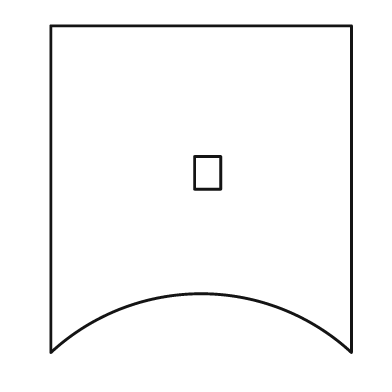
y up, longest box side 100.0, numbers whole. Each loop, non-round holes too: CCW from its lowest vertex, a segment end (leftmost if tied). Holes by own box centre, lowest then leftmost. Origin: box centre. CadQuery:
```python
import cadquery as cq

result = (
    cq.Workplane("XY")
    .moveTo(-46.0, -50.0)
    .threePointArc((0.0, -32.0), (46.0, -50.0))
    .lineTo(46.0, 50.0)
    .lineTo(-46.0, 50.0)
    .close()
    .moveTo(-2.0, 0.0)
    .lineTo(6.0, 0.0)
    .lineTo(6.0, 10.0)
    .lineTo(-2.0, 10.0)
    .close()
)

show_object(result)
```